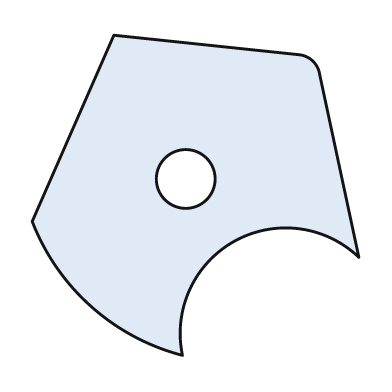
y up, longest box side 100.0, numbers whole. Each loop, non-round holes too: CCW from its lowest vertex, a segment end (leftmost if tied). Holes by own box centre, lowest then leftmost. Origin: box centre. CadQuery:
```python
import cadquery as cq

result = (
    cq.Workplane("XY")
    .moveTo(-4.0, -49.0)
    .threePointArc((12.0, -14.0), (50.0, -19.0))
    .lineTo(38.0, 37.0)
    .threePointArc((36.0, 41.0), (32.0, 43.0))
    .lineTo(-25.0, 49.0)
    .lineTo(-50.0, -8.0)
    .threePointArc((-32.0, -34.0), (-4.0, -49.0))
    .close()
    .moveTo(-3.0, 5.0)
    .circle(9.0)
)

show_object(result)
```